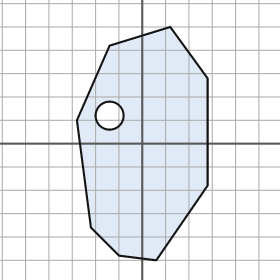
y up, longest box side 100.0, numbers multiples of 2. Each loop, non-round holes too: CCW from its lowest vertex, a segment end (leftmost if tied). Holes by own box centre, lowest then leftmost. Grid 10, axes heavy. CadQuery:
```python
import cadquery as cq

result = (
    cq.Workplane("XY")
    .moveTo(6.0, -50.0)
    .lineTo(28.0, -18.0)
    .lineTo(28.0, 28.0)
    .lineTo(12.0, 50.0)
    .lineTo(-14.0, 42.0)
    .lineTo(-28.0, 10.0)
    .lineTo(-22.0, -36.0)
    .lineTo(-10.0, -48.0)
    .close()
    .moveTo(-14.0, 12.0)
    .circle(6.0)
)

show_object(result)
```